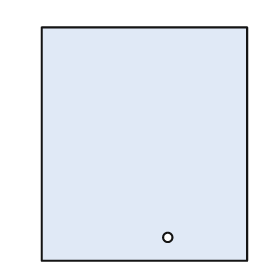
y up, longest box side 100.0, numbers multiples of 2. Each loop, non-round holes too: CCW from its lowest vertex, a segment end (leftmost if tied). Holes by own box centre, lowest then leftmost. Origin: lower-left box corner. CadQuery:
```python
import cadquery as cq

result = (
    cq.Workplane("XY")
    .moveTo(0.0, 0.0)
    .lineTo(88.0, 0.0)
    .lineTo(88.0, 100.0)
    .lineTo(0.0, 100.0)
    .close()
    .moveTo(54.0, 10.0)
    .circle(2.0)
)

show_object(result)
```